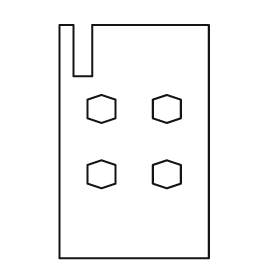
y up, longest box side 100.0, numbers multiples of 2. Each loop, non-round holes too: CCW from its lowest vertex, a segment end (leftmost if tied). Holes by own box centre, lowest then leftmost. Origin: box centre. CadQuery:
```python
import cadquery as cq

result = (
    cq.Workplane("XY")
    .moveTo(-32.0, -50.0)
    .lineTo(32.0, -50.0)
    .lineTo(32.0, 50.0)
    .lineTo(-18.0, 50.0)
    .lineTo(-18.0, 28.0)
    .lineTo(-26.0, 28.0)
    .lineTo(-26.0, 50.0)
    .lineTo(-32.0, 50.0)
    .close()
    .moveTo(-14.0, -20.0)
    .lineTo(-8.0, -18.0)
    .lineTo(-8.0, -10.0)
    .lineTo(-14.0, -8.0)
    .lineTo(-20.0, -10.0)
    .lineTo(-20.0, -18.0)
    .close()
    .moveTo(14.0, -20.0)
    .lineTo(20.0, -18.0)
    .lineTo(20.0, -10.0)
    .lineTo(14.0, -8.0)
    .lineTo(8.0, -10.0)
    .lineTo(8.0, -18.0)
    .close()
    .moveTo(-14.0, 8.0)
    .lineTo(-8.0, 10.0)
    .lineTo(-8.0, 18.0)
    .lineTo(-14.0, 20.0)
    .lineTo(-20.0, 18.0)
    .lineTo(-20.0, 10.0)
    .close()
    .moveTo(14.0, 8.0)
    .lineTo(20.0, 10.0)
    .lineTo(20.0, 18.0)
    .lineTo(14.0, 20.0)
    .lineTo(8.0, 18.0)
    .lineTo(8.0, 10.0)
    .close()
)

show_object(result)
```